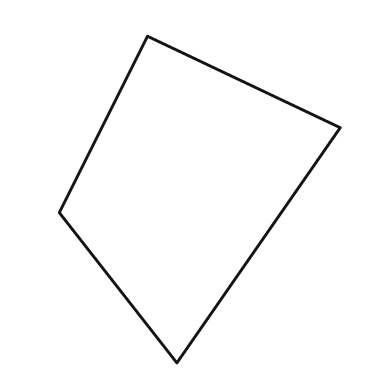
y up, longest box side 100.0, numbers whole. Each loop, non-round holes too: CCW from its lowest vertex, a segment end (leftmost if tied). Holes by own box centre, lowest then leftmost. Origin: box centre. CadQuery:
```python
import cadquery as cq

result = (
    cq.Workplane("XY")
    .moveTo(-7.0, -50.0)
    .lineTo(43.0, 22.0)
    .lineTo(-16.0, 50.0)
    .lineTo(-43.0, -4.0)
    .close()
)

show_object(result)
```